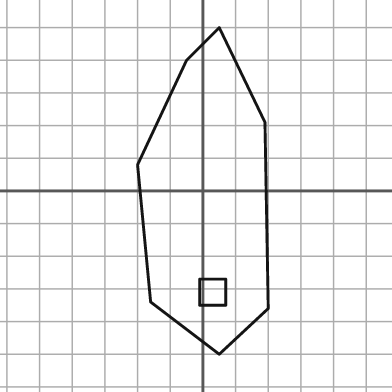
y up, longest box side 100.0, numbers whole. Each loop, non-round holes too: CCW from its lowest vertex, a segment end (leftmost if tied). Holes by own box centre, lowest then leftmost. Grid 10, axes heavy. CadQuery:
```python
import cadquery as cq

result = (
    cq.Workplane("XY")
    .moveTo(5.0, -50.0)
    .lineTo(20.0, -36.0)
    .lineTo(19.0, 21.0)
    .lineTo(5.0, 50.0)
    .lineTo(-5.0, 40.0)
    .lineTo(-20.0, 8.0)
    .lineTo(-16.0, -34.0)
    .close()
    .moveTo(-1.0, -35.0)
    .lineTo(7.0, -35.0)
    .lineTo(7.0, -27.0)
    .lineTo(-1.0, -27.0)
    .close()
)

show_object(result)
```